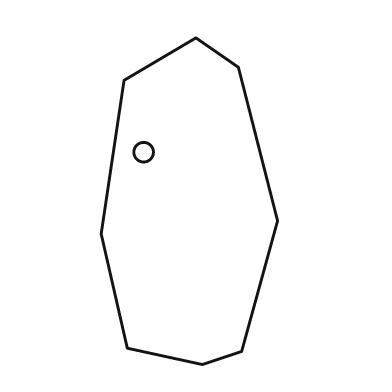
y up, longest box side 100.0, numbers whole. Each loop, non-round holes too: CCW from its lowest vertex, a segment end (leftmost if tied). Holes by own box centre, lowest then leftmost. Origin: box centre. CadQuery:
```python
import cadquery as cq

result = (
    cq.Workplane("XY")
    .moveTo(4.0, -50.0)
    .lineTo(16.0, -46.0)
    .lineTo(27.0, -6.0)
    .lineTo(15.0, 41.0)
    .lineTo(2.0, 50.0)
    .lineTo(-20.0, 37.0)
    .lineTo(-27.0, -10.0)
    .lineTo(-19.0, -45.0)
    .close()
    .moveTo(-14.0, 15.0)
    .circle(3.0)
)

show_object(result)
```